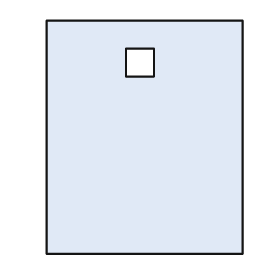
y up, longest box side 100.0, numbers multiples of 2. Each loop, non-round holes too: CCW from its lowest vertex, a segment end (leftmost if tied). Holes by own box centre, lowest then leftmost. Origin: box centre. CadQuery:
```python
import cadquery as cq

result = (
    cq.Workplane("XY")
    .moveTo(-42.0, -50.0)
    .lineTo(42.0, -50.0)
    .lineTo(42.0, 50.0)
    .lineTo(-42.0, 50.0)
    .close()
    .moveTo(-8.0, 26.0)
    .lineTo(4.0, 26.0)
    .lineTo(4.0, 38.0)
    .lineTo(-8.0, 38.0)
    .close()
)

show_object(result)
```